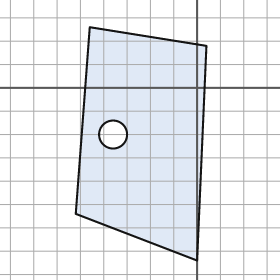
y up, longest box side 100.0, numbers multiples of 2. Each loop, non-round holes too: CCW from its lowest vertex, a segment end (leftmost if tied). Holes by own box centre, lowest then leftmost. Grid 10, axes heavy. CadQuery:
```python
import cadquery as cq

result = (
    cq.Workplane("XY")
    .moveTo(0.0, -74.0)
    .lineTo(4.0, 18.0)
    .lineTo(-46.0, 26.0)
    .lineTo(-52.0, -54.0)
    .close()
    .moveTo(-36.0, -20.0)
    .circle(6.0)
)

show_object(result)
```